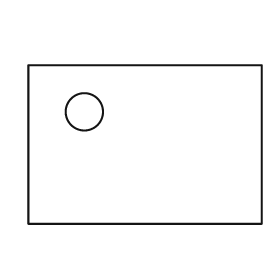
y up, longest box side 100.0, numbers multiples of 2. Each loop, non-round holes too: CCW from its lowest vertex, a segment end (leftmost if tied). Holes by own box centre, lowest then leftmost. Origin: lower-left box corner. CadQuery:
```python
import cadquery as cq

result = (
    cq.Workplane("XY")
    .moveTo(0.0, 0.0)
    .lineTo(100.0, 0.0)
    .lineTo(100.0, 68.0)
    .lineTo(0.0, 68.0)
    .close()
    .moveTo(24.0, 48.0)
    .circle(8.0)
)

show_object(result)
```